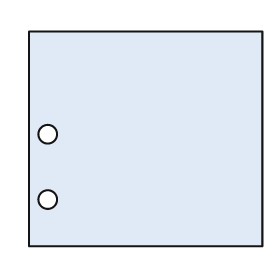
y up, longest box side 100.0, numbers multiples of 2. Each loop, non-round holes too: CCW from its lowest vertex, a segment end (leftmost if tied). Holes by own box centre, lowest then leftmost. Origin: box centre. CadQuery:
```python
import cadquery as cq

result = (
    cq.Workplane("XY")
    .moveTo(-50.0, -46.0)
    .lineTo(50.0, -46.0)
    .lineTo(50.0, 46.0)
    .lineTo(-50.0, 46.0)
    .close()
    .moveTo(-42.0, -26.0)
    .circle(4.0)
    .moveTo(-42.0, 2.0)
    .circle(4.0)
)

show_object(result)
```